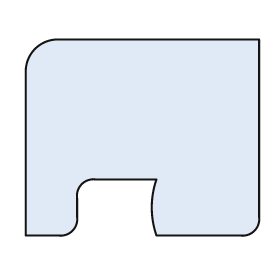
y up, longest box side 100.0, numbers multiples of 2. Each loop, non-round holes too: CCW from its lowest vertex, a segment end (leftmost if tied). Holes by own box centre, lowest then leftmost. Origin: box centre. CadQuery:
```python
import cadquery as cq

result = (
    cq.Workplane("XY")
    .moveTo(-50.0, -42.0)
    .lineTo(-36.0, -42.0)
    .threePointArc((-30.0, -40.0), (-28.0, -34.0))
    .lineTo(-28.0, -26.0)
    .threePointArc((-26.0, -20.0), (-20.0, -18.0))
    .lineTo(6.0, -18.0)
    .threePointArc((4.0, -30.0), (6.0, -42.0))
    .lineTo(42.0, -42.0)
    .threePointArc((48.0, -40.0), (50.0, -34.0))
    .lineTo(50.0, 42.0)
    .lineTo(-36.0, 42.0)
    .threePointArc((-46.0, 38.0), (-50.0, 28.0))
    .close()
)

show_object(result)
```